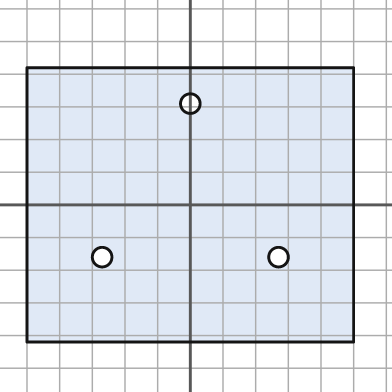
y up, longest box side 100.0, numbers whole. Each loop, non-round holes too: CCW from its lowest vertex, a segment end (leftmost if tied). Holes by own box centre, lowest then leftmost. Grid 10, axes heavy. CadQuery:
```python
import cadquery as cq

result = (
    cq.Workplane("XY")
    .moveTo(-50.0, -42.0)
    .lineTo(50.0, -42.0)
    .lineTo(50.0, 42.0)
    .lineTo(-50.0, 42.0)
    .close()
    .moveTo(-27.0, -16.0)
    .circle(3.0)
    .moveTo(27.0, -16.0)
    .circle(3.0)
    .moveTo(0.0, 31.0)
    .circle(3.0)
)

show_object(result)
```